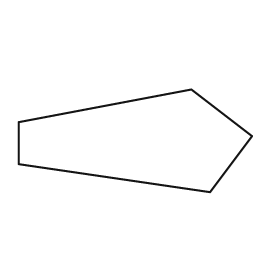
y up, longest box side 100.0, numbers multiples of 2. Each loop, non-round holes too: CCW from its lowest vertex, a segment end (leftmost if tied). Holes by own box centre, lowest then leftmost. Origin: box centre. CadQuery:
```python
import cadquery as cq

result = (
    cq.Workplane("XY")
    .moveTo(32.0, -22.0)
    .lineTo(50.0, 2.0)
    .lineTo(24.0, 22.0)
    .lineTo(-50.0, 8.0)
    .lineTo(-50.0, -10.0)
    .close()
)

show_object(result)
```